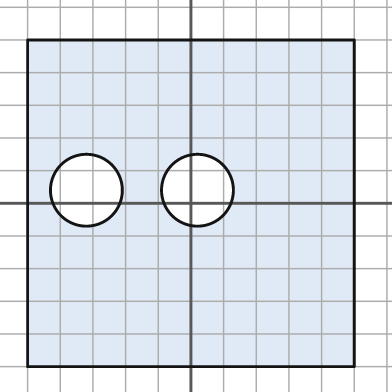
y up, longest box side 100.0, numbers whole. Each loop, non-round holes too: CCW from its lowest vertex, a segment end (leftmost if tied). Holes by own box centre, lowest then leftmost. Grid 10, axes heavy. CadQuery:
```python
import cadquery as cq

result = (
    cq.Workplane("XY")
    .moveTo(-50.0, -50.0)
    .lineTo(50.0, -50.0)
    .lineTo(50.0, 50.0)
    .lineTo(-50.0, 50.0)
    .close()
    .moveTo(-32.0, 4.0)
    .circle(11.0)
    .moveTo(2.0, 4.0)
    .circle(11.0)
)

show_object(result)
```